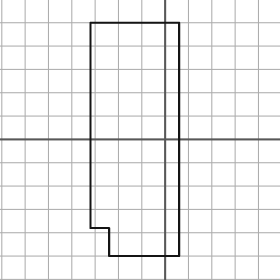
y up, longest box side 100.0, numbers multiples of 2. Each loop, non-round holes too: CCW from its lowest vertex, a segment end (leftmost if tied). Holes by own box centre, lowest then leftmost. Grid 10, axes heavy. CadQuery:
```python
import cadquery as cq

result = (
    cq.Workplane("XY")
    .moveTo(-24.0, -50.0)
    .lineTo(6.0, -50.0)
    .lineTo(6.0, 50.0)
    .lineTo(-32.0, 50.0)
    .lineTo(-32.0, -38.0)
    .lineTo(-24.0, -38.0)
    .close()
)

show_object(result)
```